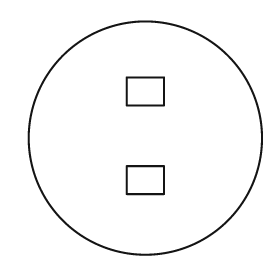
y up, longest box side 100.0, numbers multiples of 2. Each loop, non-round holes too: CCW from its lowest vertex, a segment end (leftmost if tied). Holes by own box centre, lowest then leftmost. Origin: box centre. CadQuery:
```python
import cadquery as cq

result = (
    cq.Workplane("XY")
    .moveTo(0.0, 0.0)
    .circle(50.0)
    .moveTo(-8.0, -24.0)
    .lineTo(8.0, -24.0)
    .lineTo(8.0, -12.0)
    .lineTo(-8.0, -12.0)
    .close()
    .moveTo(-8.0, 14.0)
    .lineTo(8.0, 14.0)
    .lineTo(8.0, 26.0)
    .lineTo(-8.0, 26.0)
    .close()
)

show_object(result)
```